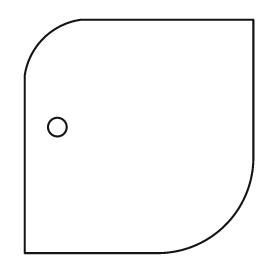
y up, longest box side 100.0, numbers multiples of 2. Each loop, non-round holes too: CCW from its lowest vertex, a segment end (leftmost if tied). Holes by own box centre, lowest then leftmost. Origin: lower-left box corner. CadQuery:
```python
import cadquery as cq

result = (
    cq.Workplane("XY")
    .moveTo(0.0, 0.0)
    .lineTo(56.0, 0.0)
    .threePointArc((86.0, 12.0), (98.0, 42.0))
    .lineTo(98.0, 100.0)
    .lineTo(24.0, 100.0)
    .threePointArc((8.0, 92.0), (0.0, 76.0))
    .close()
    .moveTo(14.0, 54.0)
    .circle(4.0)
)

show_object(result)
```